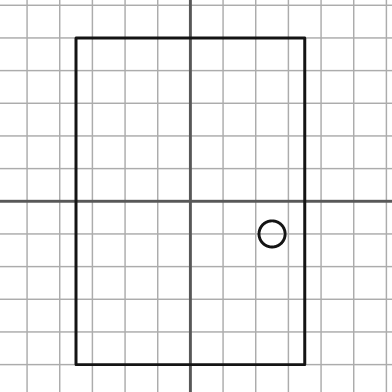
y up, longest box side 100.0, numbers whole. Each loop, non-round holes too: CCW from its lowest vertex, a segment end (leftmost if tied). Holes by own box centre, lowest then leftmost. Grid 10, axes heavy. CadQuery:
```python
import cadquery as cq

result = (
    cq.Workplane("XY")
    .moveTo(-35.0, -50.0)
    .lineTo(35.0, -50.0)
    .lineTo(35.0, 50.0)
    .lineTo(-35.0, 50.0)
    .close()
    .moveTo(25.0, -10.0)
    .circle(4.0)
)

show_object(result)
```